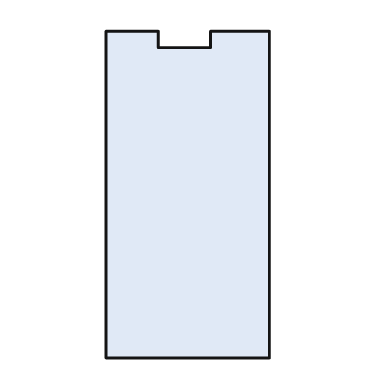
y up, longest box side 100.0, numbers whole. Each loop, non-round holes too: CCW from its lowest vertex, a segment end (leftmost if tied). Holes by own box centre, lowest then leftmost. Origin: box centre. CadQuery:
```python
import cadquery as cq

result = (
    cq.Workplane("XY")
    .moveTo(-25.0, -50.0)
    .lineTo(25.0, -50.0)
    .lineTo(25.0, 50.0)
    .lineTo(7.0, 50.0)
    .lineTo(7.0, 45.0)
    .lineTo(-9.0, 45.0)
    .lineTo(-9.0, 50.0)
    .lineTo(-25.0, 50.0)
    .close()
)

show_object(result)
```